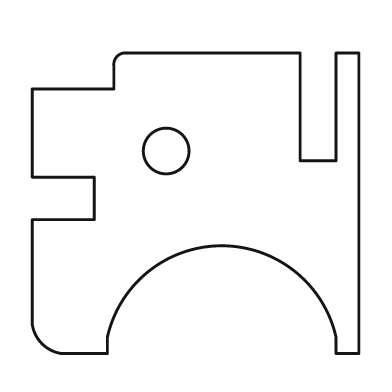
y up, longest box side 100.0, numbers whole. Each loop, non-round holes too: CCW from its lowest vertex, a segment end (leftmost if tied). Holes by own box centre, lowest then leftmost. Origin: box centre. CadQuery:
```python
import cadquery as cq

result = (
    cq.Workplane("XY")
    .moveTo(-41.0, -46.0)
    .lineTo(-27.0, -46.0)
    .lineTo(-27.0, -41.0)
    .threePointArc((8.0, -13.0), (43.0, -41.0))
    .lineTo(43.0, -46.0)
    .lineTo(50.0, -46.0)
    .lineTo(50.0, 46.0)
    .lineTo(43.0, 46.0)
    .lineTo(43.0, 13.0)
    .lineTo(32.0, 13.0)
    .lineTo(32.0, 46.0)
    .lineTo(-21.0, 46.0)
    .threePointArc((-24.0, 45.0), (-25.0, 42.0))
    .lineTo(-25.0, 35.0)
    .lineTo(-50.0, 35.0)
    .lineTo(-50.0, 8.0)
    .lineTo(-31.0, 8.0)
    .lineTo(-31.0, -5.0)
    .lineTo(-50.0, -5.0)
    .lineTo(-50.0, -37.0)
    .threePointArc((-47.0, -43.0), (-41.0, -46.0))
    .close()
    .moveTo(-9.0, 16.0)
    .circle(7.0)
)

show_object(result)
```